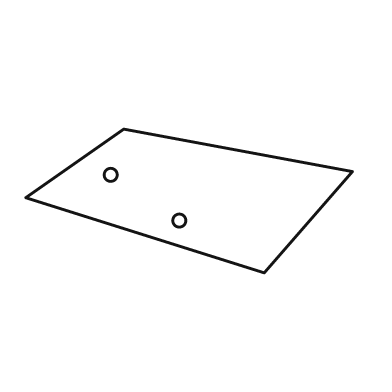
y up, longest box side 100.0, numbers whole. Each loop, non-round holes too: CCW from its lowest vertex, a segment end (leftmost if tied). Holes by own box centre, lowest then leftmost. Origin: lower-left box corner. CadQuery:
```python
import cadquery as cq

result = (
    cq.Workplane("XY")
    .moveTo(73.0, 0.0)
    .lineTo(100.0, 31.0)
    .lineTo(30.0, 44.0)
    .lineTo(0.0, 23.0)
    .close()
    .moveTo(47.0, 16.0)
    .circle(2.0)
    .moveTo(26.0, 30.0)
    .circle(2.0)
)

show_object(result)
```